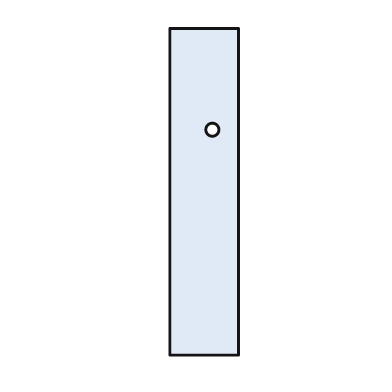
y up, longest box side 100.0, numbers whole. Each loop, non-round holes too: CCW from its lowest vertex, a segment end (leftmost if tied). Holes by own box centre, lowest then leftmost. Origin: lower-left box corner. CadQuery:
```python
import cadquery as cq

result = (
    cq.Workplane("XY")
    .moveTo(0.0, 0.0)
    .lineTo(21.0, 0.0)
    .lineTo(21.0, 100.0)
    .lineTo(0.0, 100.0)
    .close()
    .moveTo(13.0, 69.0)
    .circle(2.0)
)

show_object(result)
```